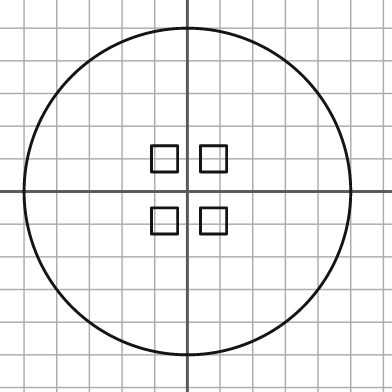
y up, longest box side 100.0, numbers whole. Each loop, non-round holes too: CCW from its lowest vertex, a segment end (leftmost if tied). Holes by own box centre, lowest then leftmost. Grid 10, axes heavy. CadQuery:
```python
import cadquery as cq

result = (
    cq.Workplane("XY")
    .moveTo(0.0, 0.0)
    .circle(50.0)
    .moveTo(-11.0, -13.0)
    .lineTo(-3.0, -13.0)
    .lineTo(-3.0, -5.0)
    .lineTo(-11.0, -5.0)
    .close()
    .moveTo(4.0, -13.0)
    .lineTo(12.0, -13.0)
    .lineTo(12.0, -5.0)
    .lineTo(4.0, -5.0)
    .close()
    .moveTo(-11.0, 6.0)
    .lineTo(-3.0, 6.0)
    .lineTo(-3.0, 14.0)
    .lineTo(-11.0, 14.0)
    .close()
    .moveTo(4.0, 6.0)
    .lineTo(12.0, 6.0)
    .lineTo(12.0, 14.0)
    .lineTo(4.0, 14.0)
    .close()
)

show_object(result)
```